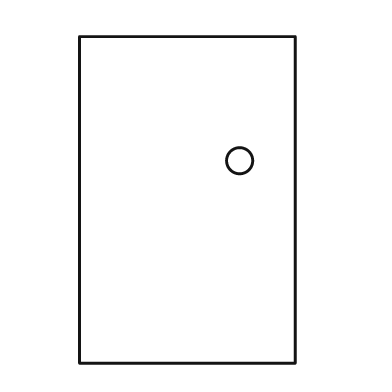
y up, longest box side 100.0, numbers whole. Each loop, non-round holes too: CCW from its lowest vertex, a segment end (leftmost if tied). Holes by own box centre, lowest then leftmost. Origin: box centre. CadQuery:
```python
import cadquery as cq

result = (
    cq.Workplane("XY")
    .moveTo(-33.0, -50.0)
    .lineTo(33.0, -50.0)
    .lineTo(33.0, 50.0)
    .lineTo(-33.0, 50.0)
    .close()
    .moveTo(16.0, 12.0)
    .circle(4.0)
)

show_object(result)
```